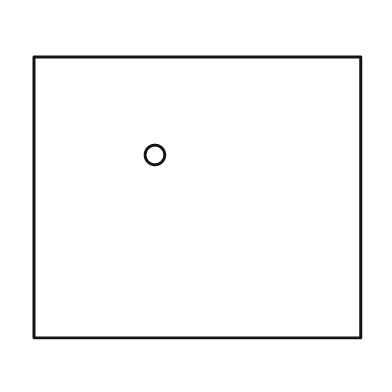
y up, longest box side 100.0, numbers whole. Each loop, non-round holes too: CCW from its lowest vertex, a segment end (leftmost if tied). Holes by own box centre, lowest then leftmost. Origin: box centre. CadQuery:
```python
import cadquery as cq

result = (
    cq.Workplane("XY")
    .moveTo(-50.0, -43.0)
    .lineTo(50.0, -43.0)
    .lineTo(50.0, 43.0)
    .lineTo(-50.0, 43.0)
    .close()
    .moveTo(-13.0, 13.0)
    .circle(3.0)
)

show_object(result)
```